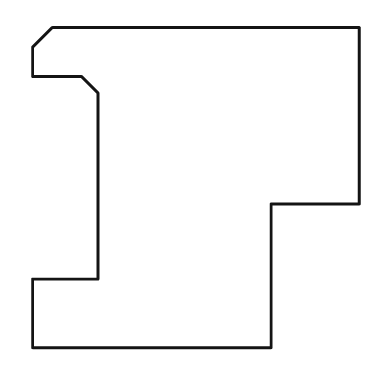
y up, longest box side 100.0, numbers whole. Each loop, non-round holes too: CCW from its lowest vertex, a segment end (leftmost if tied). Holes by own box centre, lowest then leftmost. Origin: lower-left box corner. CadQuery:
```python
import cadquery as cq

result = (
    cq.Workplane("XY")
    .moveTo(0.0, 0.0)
    .lineTo(73.0, 0.0)
    .lineTo(73.0, 44.0)
    .lineTo(100.0, 44.0)
    .lineTo(100.0, 98.0)
    .lineTo(6.0, 98.0)
    .lineTo(0.0, 92.0)
    .lineTo(0.0, 83.0)
    .lineTo(15.0, 83.0)
    .lineTo(20.0, 78.0)
    .lineTo(20.0, 21.0)
    .lineTo(0.0, 21.0)
    .close()
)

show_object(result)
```